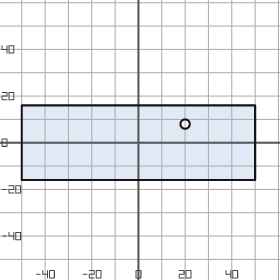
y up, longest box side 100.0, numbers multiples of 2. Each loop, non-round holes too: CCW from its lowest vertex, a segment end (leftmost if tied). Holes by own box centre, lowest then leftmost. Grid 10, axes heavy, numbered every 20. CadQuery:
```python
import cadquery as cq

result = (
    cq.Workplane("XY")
    .moveTo(-50.0, -16.0)
    .lineTo(50.0, -16.0)
    .lineTo(50.0, 16.0)
    .lineTo(-50.0, 16.0)
    .close()
    .moveTo(20.0, 8.0)
    .circle(2.0)
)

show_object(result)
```